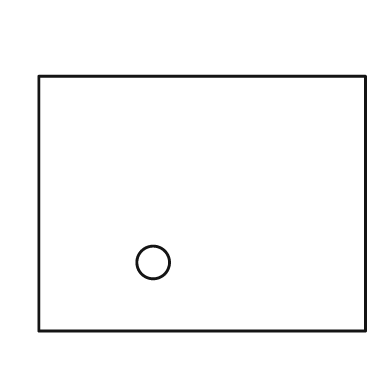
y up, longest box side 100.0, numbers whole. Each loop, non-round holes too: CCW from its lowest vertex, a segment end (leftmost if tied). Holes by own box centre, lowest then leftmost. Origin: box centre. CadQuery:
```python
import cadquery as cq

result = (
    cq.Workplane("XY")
    .moveTo(-50.0, -39.0)
    .lineTo(50.0, -39.0)
    .lineTo(50.0, 39.0)
    .lineTo(-50.0, 39.0)
    .close()
    .moveTo(-15.0, -18.0)
    .circle(5.0)
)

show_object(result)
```